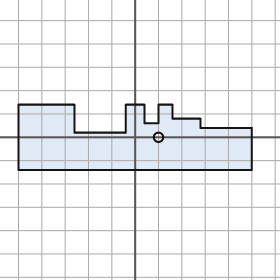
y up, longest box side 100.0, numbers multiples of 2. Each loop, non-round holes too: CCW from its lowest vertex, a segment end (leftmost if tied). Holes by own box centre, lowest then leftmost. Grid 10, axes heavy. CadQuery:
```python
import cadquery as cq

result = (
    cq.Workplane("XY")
    .moveTo(-50.0, -14.0)
    .lineTo(50.0, -14.0)
    .lineTo(50.0, 4.0)
    .lineTo(28.0, 4.0)
    .lineTo(28.0, 8.0)
    .lineTo(16.0, 8.0)
    .lineTo(16.0, 14.0)
    .lineTo(10.0, 14.0)
    .lineTo(10.0, 6.0)
    .lineTo(4.0, 6.0)
    .lineTo(4.0, 14.0)
    .lineTo(-4.0, 14.0)
    .lineTo(-4.0, 2.0)
    .lineTo(-26.0, 2.0)
    .lineTo(-26.0, 14.0)
    .lineTo(-50.0, 14.0)
    .close()
    .moveTo(10.0, 0.0)
    .circle(2.0)
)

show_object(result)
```